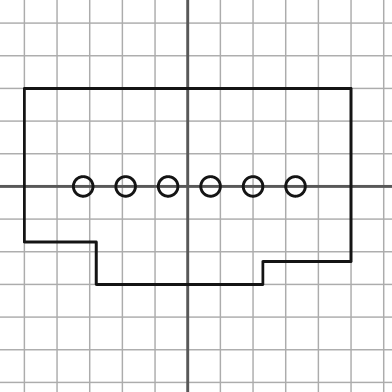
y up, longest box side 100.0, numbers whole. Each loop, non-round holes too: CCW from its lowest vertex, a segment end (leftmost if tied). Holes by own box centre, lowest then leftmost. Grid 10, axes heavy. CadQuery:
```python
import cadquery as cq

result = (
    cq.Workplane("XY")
    .moveTo(-28.0, -30.0)
    .lineTo(23.0, -30.0)
    .lineTo(23.0, -23.0)
    .lineTo(50.0, -23.0)
    .lineTo(50.0, 30.0)
    .lineTo(-50.0, 30.0)
    .lineTo(-50.0, -17.0)
    .lineTo(-28.0, -17.0)
    .close()
    .moveTo(-32.0, 0.0)
    .circle(3.0)
    .moveTo(-19.0, 0.0)
    .circle(3.0)
    .moveTo(-6.0, 0.0)
    .circle(3.0)
    .moveTo(7.0, 0.0)
    .circle(3.0)
    .moveTo(20.0, 0.0)
    .circle(3.0)
    .moveTo(33.0, 0.0)
    .circle(3.0)
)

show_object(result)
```